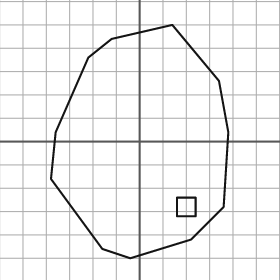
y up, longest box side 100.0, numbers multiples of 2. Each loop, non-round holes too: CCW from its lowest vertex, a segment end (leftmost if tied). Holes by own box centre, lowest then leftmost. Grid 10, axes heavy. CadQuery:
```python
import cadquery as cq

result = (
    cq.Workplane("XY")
    .moveTo(-4.0, -50.0)
    .lineTo(22.0, -42.0)
    .lineTo(36.0, -28.0)
    .lineTo(38.0, 4.0)
    .lineTo(34.0, 26.0)
    .lineTo(14.0, 50.0)
    .lineTo(-12.0, 44.0)
    .lineTo(-22.0, 36.0)
    .lineTo(-36.0, 4.0)
    .lineTo(-38.0, -16.0)
    .lineTo(-16.0, -46.0)
    .close()
    .moveTo(16.0, -32.0)
    .lineTo(24.0, -32.0)
    .lineTo(24.0, -24.0)
    .lineTo(16.0, -24.0)
    .close()
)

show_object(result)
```